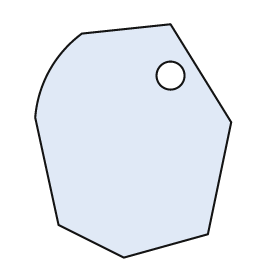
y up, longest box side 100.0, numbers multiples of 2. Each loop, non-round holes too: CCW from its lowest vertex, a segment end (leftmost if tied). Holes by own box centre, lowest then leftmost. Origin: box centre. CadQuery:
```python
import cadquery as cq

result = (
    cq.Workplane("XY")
    .moveTo(-4.0, -50.0)
    .lineTo(32.0, -40.0)
    .lineTo(42.0, 8.0)
    .lineTo(16.0, 50.0)
    .lineTo(-22.0, 46.0)
    .threePointArc((-36.0, 30.0), (-42.0, 10.0))
    .lineTo(-32.0, -36.0)
    .close()
    .moveTo(16.0, 28.0)
    .circle(6.0)
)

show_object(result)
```